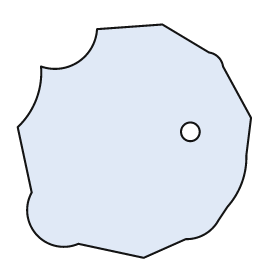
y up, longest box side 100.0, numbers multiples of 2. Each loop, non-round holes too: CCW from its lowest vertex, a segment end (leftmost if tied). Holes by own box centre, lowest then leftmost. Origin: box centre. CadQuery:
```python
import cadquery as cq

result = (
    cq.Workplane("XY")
    .moveTo(4.0, -50.0)
    .lineTo(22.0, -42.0)
    .threePointArc((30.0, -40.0), (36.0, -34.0))
    .lineTo(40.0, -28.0)
    .threePointArc((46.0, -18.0), (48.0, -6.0))
    .lineTo(50.0, 10.0)
    .lineTo(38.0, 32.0)
    .threePointArc((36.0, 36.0), (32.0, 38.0))
    .lineTo(12.0, 50.0)
    .lineTo(-16.0, 48.0)
    .threePointArc((-24.0, 34.0), (-40.0, 32.0))
    .threePointArc((-42.0, 18.0), (-50.0, 6.0))
    .lineTo(-44.0, -22.0)
    .threePointArc((-42.0, -40.0), (-24.0, -44.0))
    .close()
    .moveTo(24.0, 4.0)
    .circle(4.0)
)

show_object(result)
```